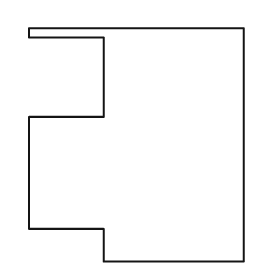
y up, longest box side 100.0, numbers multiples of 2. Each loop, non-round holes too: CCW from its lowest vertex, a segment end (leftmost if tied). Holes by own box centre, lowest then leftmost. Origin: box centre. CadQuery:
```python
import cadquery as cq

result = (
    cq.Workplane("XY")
    .moveTo(-14.0, -50.0)
    .lineTo(46.0, -50.0)
    .lineTo(46.0, 50.0)
    .lineTo(-46.0, 50.0)
    .lineTo(-46.0, 46.0)
    .lineTo(-14.0, 46.0)
    .lineTo(-14.0, 12.0)
    .lineTo(-46.0, 12.0)
    .lineTo(-46.0, -36.0)
    .lineTo(-14.0, -36.0)
    .close()
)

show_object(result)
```